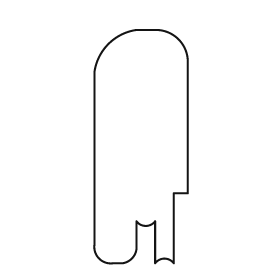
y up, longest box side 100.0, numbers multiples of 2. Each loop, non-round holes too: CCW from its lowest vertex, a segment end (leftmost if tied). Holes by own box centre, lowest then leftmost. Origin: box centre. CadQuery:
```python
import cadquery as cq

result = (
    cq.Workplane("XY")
    .moveTo(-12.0, -50.0)
    .lineTo(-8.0, -50.0)
    .threePointArc((-4.0, -48.0), (-2.0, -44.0))
    .lineTo(-2.0, -32.0)
    .threePointArc((2.0, -34.0), (6.0, -32.0))
    .lineTo(6.0, -50.0)
    .threePointArc((10.0, -48.0), (14.0, -50.0))
    .lineTo(14.0, -20.0)
    .lineTo(20.0, -20.0)
    .lineTo(20.0, 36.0)
    .threePointArc((16.0, 46.0), (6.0, 50.0))
    .lineTo(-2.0, 50.0)
    .threePointArc((-14.0, 44.0), (-20.0, 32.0))
    .lineTo(-20.0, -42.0)
    .threePointArc((-18.0, -48.0), (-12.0, -50.0))
    .close()
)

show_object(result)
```